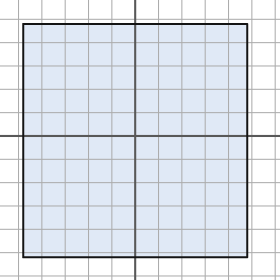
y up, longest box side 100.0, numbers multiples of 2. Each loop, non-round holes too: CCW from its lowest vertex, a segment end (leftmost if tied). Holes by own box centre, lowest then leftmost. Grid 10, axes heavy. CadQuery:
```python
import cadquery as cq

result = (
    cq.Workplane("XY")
    .moveTo(-48.0, -52.0)
    .lineTo(48.0, -52.0)
    .lineTo(48.0, 48.0)
    .lineTo(-48.0, 48.0)
    .close()
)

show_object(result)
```